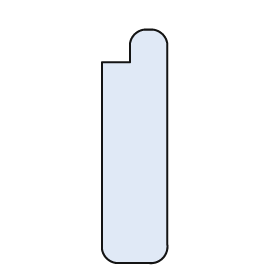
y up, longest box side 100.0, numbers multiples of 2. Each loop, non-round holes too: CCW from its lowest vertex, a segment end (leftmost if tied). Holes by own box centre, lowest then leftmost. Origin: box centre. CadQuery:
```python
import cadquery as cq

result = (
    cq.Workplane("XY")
    .moveTo(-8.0, -50.0)
    .lineTo(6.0, -50.0)
    .threePointArc((12.0, -48.0), (14.0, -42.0))
    .lineTo(14.0, 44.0)
    .threePointArc((12.0, 48.0), (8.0, 50.0))
    .lineTo(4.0, 50.0)
    .threePointArc((0.0, 48.0), (-2.0, 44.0))
    .lineTo(-2.0, 36.0)
    .lineTo(-14.0, 36.0)
    .lineTo(-14.0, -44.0)
    .threePointArc((-12.0, -48.0), (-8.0, -50.0))
    .close()
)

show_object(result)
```